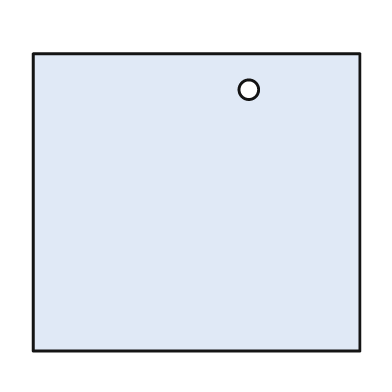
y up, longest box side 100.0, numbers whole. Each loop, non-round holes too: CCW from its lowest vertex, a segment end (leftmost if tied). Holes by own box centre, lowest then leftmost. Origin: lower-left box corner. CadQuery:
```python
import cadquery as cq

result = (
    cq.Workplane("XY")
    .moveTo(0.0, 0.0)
    .lineTo(100.0, 0.0)
    .lineTo(100.0, 91.0)
    .lineTo(0.0, 91.0)
    .close()
    .moveTo(66.0, 80.0)
    .circle(3.0)
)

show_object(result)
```